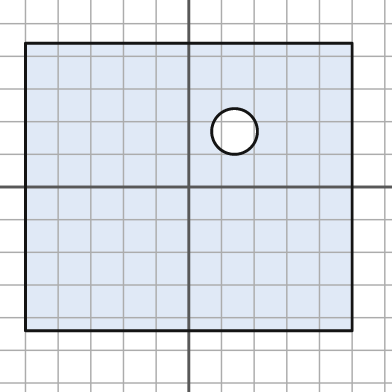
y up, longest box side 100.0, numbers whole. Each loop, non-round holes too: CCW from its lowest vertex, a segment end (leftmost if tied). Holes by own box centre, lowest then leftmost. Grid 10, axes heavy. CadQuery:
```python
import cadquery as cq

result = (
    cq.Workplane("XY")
    .moveTo(-50.0, -44.0)
    .lineTo(50.0, -44.0)
    .lineTo(50.0, 44.0)
    .lineTo(-50.0, 44.0)
    .close()
    .moveTo(14.0, 17.0)
    .circle(7.0)
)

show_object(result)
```